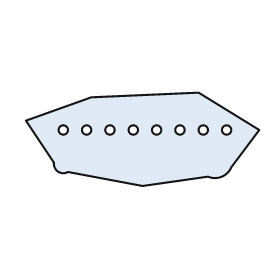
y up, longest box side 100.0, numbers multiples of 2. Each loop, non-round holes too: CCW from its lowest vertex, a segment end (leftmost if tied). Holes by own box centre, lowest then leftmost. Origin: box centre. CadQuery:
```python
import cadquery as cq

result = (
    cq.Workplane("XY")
    .moveTo(0.0, -20.0)
    .lineTo(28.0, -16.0)
    .threePointArc((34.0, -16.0), (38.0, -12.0))
    .lineTo(50.0, 4.0)
    .lineTo(24.0, 20.0)
    .lineTo(-22.0, 18.0)
    .lineTo(-50.0, 8.0)
    .lineTo(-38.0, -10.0)
    .threePointArc((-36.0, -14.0), (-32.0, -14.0))
    .close()
    .moveTo(-34.0, 4.0)
    .circle(2.0)
    .moveTo(-24.0, 4.0)
    .circle(2.0)
    .moveTo(-14.0, 4.0)
    .circle(2.0)
    .moveTo(-4.0, 4.0)
    .circle(2.0)
    .moveTo(6.0, 4.0)
    .circle(2.0)
    .moveTo(16.0, 4.0)
    .circle(2.0)
    .moveTo(26.0, 4.0)
    .circle(2.0)
    .moveTo(36.0, 4.0)
    .circle(2.0)
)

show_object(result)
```